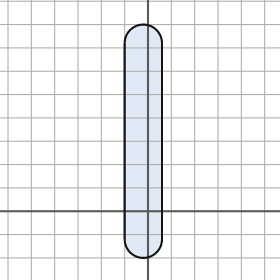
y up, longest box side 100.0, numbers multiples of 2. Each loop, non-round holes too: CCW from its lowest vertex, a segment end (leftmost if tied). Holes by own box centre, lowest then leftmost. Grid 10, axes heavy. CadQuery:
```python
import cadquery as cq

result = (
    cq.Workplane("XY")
    .moveTo(-10.0, -12.0)
    .threePointArc((-2.0, -20.0), (6.0, -12.0))
    .lineTo(6.0, 72.0)
    .threePointArc((-2.0, 80.0), (-10.0, 72.0))
    .close()
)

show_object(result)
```